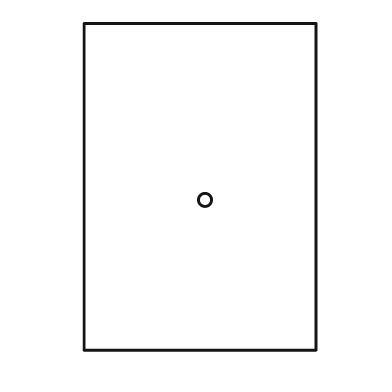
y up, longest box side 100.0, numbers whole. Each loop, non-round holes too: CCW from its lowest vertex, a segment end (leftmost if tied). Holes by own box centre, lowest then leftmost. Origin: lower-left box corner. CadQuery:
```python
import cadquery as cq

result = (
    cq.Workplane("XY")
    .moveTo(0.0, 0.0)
    .lineTo(71.0, 0.0)
    .lineTo(71.0, 100.0)
    .lineTo(0.0, 100.0)
    .close()
    .moveTo(37.0, 46.0)
    .circle(2.0)
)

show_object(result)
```